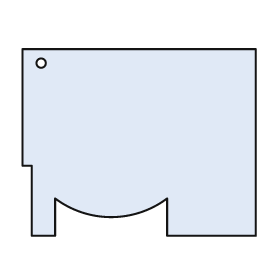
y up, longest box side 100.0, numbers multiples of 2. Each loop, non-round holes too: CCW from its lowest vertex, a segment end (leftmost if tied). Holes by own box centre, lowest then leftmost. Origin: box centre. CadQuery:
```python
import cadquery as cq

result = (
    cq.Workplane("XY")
    .moveTo(-46.0, -40.0)
    .lineTo(-36.0, -40.0)
    .lineTo(-36.0, -24.0)
    .threePointArc((-12.0, -32.0), (12.0, -24.0))
    .lineTo(12.0, -40.0)
    .lineTo(50.0, -40.0)
    .lineTo(50.0, 40.0)
    .lineTo(-50.0, 40.0)
    .lineTo(-50.0, -10.0)
    .lineTo(-46.0, -10.0)
    .close()
    .moveTo(-42.0, 34.0)
    .circle(2.0)
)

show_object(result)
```